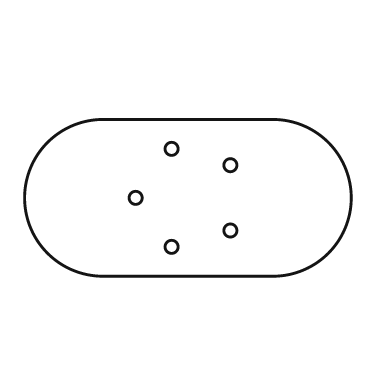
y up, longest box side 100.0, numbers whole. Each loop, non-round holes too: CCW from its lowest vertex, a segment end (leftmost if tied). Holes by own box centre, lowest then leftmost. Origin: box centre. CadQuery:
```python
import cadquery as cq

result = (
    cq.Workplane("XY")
    .moveTo(-26.0, -24.0)
    .lineTo(26.0, -24.0)
    .threePointArc((50.0, 0.0), (26.0, 24.0))
    .lineTo(-26.0, 24.0)
    .threePointArc((-50.0, 0.0), (-26.0, -24.0))
    .close()
    .moveTo(-5.0, -15.0)
    .circle(2.0)
    .moveTo(13.0, -10.0)
    .circle(2.0)
    .moveTo(-16.0, 0.0)
    .circle(2.0)
    .moveTo(13.0, 10.0)
    .circle(2.0)
    .moveTo(-5.0, 15.0)
    .circle(2.0)
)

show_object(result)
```